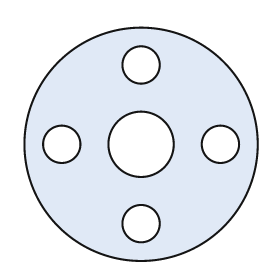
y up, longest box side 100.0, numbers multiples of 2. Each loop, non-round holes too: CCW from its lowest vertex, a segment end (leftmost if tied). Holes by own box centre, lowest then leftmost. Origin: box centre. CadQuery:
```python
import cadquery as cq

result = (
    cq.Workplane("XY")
    .moveTo(0.0, 0.0)
    .circle(50.0)
    .moveTo(0.0, -34.0)
    .circle(8.0)
    .moveTo(-34.0, 0.0)
    .circle(8.0)
    .moveTo(0.0, 0.0)
    .circle(14.0)
    .moveTo(34.0, 0.0)
    .circle(8.0)
    .moveTo(0.0, 34.0)
    .circle(8.0)
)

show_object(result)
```